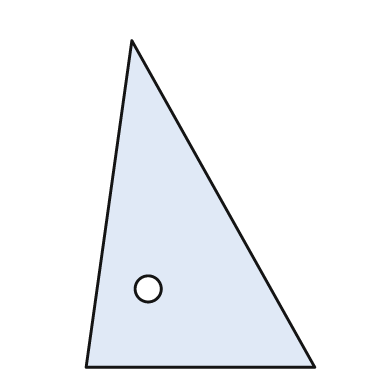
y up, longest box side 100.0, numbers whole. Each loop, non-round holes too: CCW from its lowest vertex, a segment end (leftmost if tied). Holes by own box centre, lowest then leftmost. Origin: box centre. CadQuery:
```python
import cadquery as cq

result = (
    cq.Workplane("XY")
    .moveTo(-35.0, -50.0)
    .lineTo(35.0, -50.0)
    .lineTo(-21.0, 50.0)
    .close()
    .moveTo(-16.0, -26.0)
    .circle(4.0)
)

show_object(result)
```